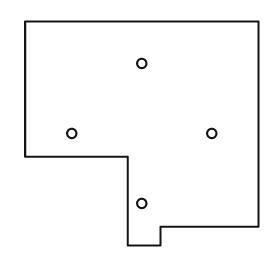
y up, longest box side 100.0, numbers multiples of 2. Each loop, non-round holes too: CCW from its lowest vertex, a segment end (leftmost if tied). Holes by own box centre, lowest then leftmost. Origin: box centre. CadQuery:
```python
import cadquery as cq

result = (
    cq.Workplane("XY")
    .moveTo(-6.0, -48.0)
    .lineTo(8.0, -48.0)
    .lineTo(8.0, -40.0)
    .lineTo(50.0, -40.0)
    .lineTo(50.0, 48.0)
    .lineTo(-50.0, 48.0)
    .lineTo(-50.0, -10.0)
    .lineTo(-6.0, -10.0)
    .close()
    .moveTo(0.0, -30.0)
    .circle(2.0)
    .moveTo(-30.0, 0.0)
    .circle(2.0)
    .moveTo(30.0, 0.0)
    .circle(2.0)
    .moveTo(0.0, 30.0)
    .circle(2.0)
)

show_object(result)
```